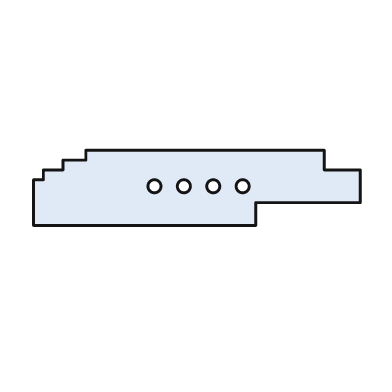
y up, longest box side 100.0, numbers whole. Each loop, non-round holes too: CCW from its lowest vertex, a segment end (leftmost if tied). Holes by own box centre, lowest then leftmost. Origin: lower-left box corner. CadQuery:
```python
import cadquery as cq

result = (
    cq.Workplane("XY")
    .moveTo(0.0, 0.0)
    .lineTo(68.0, 0.0)
    .lineTo(68.0, 7.0)
    .lineTo(100.0, 7.0)
    .lineTo(100.0, 17.0)
    .lineTo(89.0, 17.0)
    .lineTo(89.0, 23.0)
    .lineTo(16.0, 23.0)
    .lineTo(16.0, 20.0)
    .lineTo(9.0, 20.0)
    .lineTo(9.0, 17.0)
    .lineTo(3.0, 17.0)
    .lineTo(3.0, 14.0)
    .lineTo(0.0, 14.0)
    .close()
    .moveTo(37.0, 12.0)
    .circle(2.0)
    .moveTo(46.0, 12.0)
    .circle(2.0)
    .moveTo(55.0, 12.0)
    .circle(2.0)
    .moveTo(64.0, 12.0)
    .circle(2.0)
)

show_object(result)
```